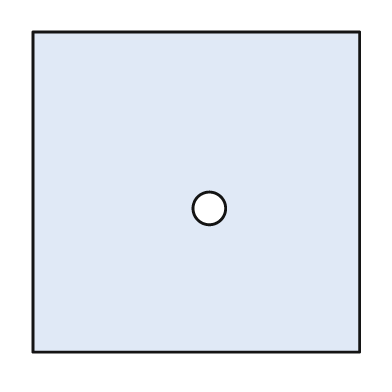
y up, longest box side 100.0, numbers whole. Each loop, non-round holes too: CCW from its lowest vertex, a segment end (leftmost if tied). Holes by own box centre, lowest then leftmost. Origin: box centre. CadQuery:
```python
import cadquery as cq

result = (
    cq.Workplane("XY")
    .moveTo(-50.0, -49.0)
    .lineTo(50.0, -49.0)
    .lineTo(50.0, 49.0)
    .lineTo(-50.0, 49.0)
    .close()
    .moveTo(4.0, -5.0)
    .circle(5.0)
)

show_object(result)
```